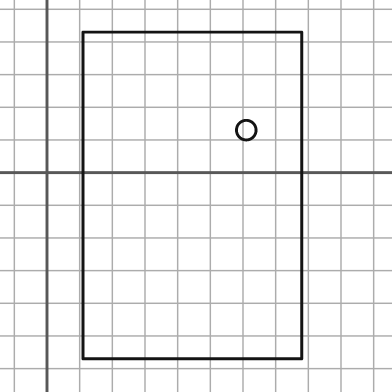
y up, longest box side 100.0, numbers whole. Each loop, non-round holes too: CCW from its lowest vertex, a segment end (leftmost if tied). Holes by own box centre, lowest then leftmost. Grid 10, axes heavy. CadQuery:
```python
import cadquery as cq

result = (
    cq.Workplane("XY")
    .moveTo(11.0, -57.0)
    .lineTo(78.0, -57.0)
    .lineTo(78.0, 43.0)
    .lineTo(11.0, 43.0)
    .close()
    .moveTo(61.0, 13.0)
    .circle(3.0)
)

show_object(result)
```